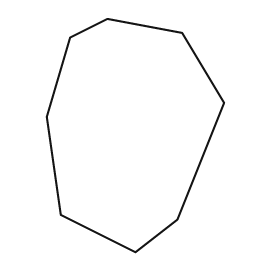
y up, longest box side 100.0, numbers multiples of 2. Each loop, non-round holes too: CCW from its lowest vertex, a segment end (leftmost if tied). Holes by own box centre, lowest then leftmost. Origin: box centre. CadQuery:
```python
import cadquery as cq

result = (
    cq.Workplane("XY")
    .moveTo(0.0, -50.0)
    .lineTo(18.0, -36.0)
    .lineTo(38.0, 14.0)
    .lineTo(20.0, 44.0)
    .lineTo(-12.0, 50.0)
    .lineTo(-28.0, 42.0)
    .lineTo(-38.0, 8.0)
    .lineTo(-32.0, -34.0)
    .close()
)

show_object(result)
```